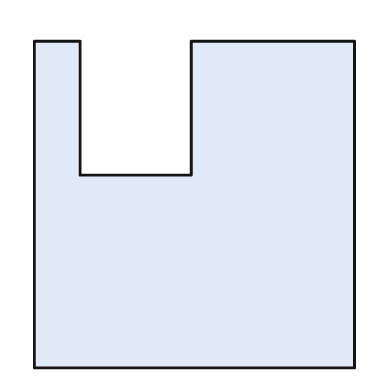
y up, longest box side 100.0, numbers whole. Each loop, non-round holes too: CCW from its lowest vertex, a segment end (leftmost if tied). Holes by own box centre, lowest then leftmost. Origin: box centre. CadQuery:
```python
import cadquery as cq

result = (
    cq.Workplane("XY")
    .moveTo(-49.0, -50.0)
    .lineTo(49.0, -50.0)
    .lineTo(49.0, 50.0)
    .lineTo(-1.0, 50.0)
    .lineTo(-1.0, 9.0)
    .lineTo(-35.0, 9.0)
    .lineTo(-35.0, 50.0)
    .lineTo(-49.0, 50.0)
    .close()
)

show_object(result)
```